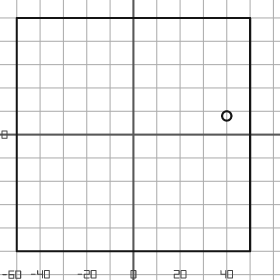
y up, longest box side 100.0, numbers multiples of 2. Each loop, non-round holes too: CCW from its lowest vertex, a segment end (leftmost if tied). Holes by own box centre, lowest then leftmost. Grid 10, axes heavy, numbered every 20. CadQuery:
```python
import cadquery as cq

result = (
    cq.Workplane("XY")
    .moveTo(-50.0, -50.0)
    .lineTo(50.0, -50.0)
    .lineTo(50.0, 50.0)
    .lineTo(-50.0, 50.0)
    .close()
    .moveTo(40.0, 8.0)
    .circle(2.0)
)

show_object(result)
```